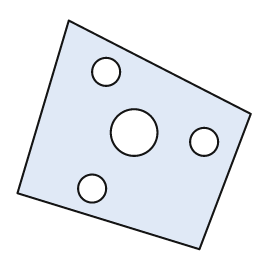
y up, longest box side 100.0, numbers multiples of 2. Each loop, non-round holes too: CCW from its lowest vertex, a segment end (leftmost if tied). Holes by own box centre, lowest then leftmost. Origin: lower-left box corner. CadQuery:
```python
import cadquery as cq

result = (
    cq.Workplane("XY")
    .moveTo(78.0, 0.0)
    .lineTo(100.0, 58.0)
    .lineTo(22.0, 98.0)
    .lineTo(0.0, 24.0)
    .close()
    .moveTo(32.0, 26.0)
    .circle(6.0)
    .moveTo(80.0, 46.0)
    .circle(6.0)
    .moveTo(50.0, 50.0)
    .circle(10.0)
    .moveTo(38.0, 76.0)
    .circle(6.0)
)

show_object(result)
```